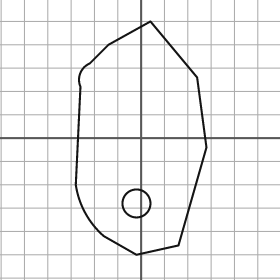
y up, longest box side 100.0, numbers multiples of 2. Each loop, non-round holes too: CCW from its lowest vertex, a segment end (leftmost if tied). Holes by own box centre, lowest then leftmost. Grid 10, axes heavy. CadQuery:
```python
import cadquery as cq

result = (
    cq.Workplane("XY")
    .moveTo(-2.0, -50.0)
    .lineTo(16.0, -46.0)
    .lineTo(28.0, -4.0)
    .lineTo(24.0, 26.0)
    .lineTo(4.0, 50.0)
    .lineTo(-14.0, 40.0)
    .lineTo(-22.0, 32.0)
    .threePointArc((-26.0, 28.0), (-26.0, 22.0))
    .lineTo(-28.0, -20.0)
    .threePointArc((-24.0, -32.0), (-16.0, -42.0))
    .close()
    .moveTo(-2.0, -28.0)
    .circle(6.0)
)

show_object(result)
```